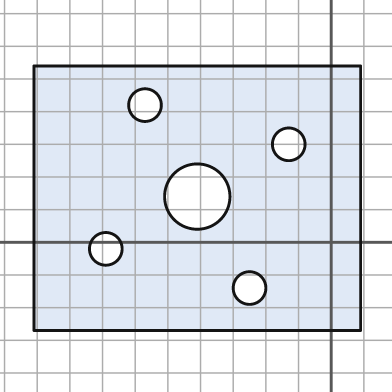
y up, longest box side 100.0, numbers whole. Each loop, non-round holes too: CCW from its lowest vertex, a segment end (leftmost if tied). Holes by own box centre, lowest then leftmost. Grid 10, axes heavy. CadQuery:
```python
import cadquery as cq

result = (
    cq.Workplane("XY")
    .moveTo(-91.0, -27.0)
    .lineTo(9.0, -27.0)
    .lineTo(9.0, 54.0)
    .lineTo(-91.0, 54.0)
    .close()
    .moveTo(-25.0, -14.0)
    .circle(5.0)
    .moveTo(-69.0, -2.0)
    .circle(5.0)
    .moveTo(-41.0, 14.0)
    .circle(10.0)
    .moveTo(-13.0, 30.0)
    .circle(5.0)
    .moveTo(-57.0, 42.0)
    .circle(5.0)
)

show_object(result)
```